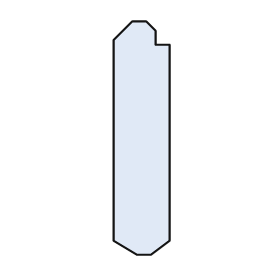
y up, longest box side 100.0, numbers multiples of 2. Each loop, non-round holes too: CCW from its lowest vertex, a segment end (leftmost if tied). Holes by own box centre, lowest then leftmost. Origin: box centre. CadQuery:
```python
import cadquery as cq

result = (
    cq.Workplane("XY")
    .moveTo(-2.0, -50.0)
    .lineTo(4.0, -50.0)
    .lineTo(12.0, -44.0)
    .lineTo(12.0, 40.0)
    .lineTo(6.0, 40.0)
    .lineTo(6.0, 46.0)
    .lineTo(2.0, 50.0)
    .lineTo(-4.0, 50.0)
    .lineTo(-12.0, 42.0)
    .lineTo(-12.0, -44.0)
    .close()
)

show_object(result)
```